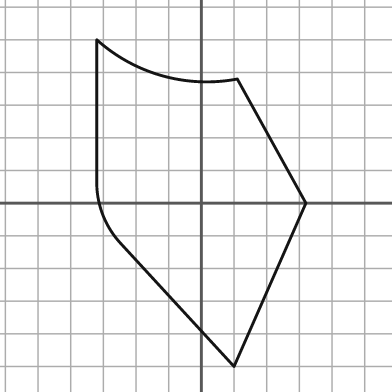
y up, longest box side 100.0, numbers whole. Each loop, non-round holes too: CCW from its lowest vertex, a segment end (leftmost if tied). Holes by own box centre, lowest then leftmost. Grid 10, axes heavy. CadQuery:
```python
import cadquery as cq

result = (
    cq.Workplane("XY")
    .moveTo(10.0, -50.0)
    .lineTo(32.0, 0.0)
    .lineTo(11.0, 38.0)
    .threePointArc((-12.0, 39.0), (-32.0, 50.0))
    .lineTo(-32.0, 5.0)
    .threePointArc((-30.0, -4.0), (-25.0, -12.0))
    .close()
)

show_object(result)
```